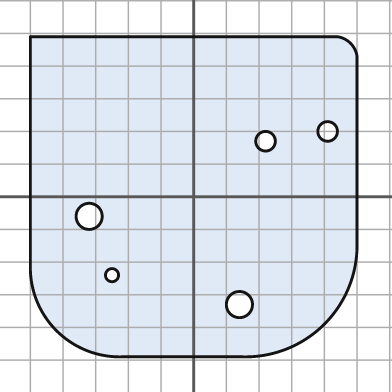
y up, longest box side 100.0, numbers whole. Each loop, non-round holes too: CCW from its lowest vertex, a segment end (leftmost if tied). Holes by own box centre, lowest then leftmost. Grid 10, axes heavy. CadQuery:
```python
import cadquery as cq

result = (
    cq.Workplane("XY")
    .moveTo(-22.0, -49.0)
    .lineTo(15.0, -49.0)
    .threePointArc((40.0, -39.0), (50.0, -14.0))
    .lineTo(50.0, 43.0)
    .threePointArc((48.0, 47.0), (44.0, 49.0))
    .lineTo(-50.0, 49.0)
    .lineTo(-50.0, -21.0)
    .threePointArc((-42.0, -41.0), (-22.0, -49.0))
    .close()
    .moveTo(14.0, -33.0)
    .circle(4.0)
    .moveTo(-25.0, -24.0)
    .circle(2.0)
    .moveTo(-32.0, -6.0)
    .circle(4.0)
    .moveTo(22.0, 17.0)
    .circle(3.0)
    .moveTo(41.0, 20.0)
    .circle(3.0)
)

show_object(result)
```